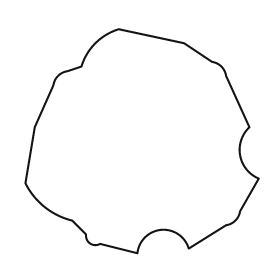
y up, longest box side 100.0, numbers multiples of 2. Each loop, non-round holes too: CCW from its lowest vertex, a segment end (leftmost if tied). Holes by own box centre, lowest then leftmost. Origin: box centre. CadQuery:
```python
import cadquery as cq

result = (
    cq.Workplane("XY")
    .moveTo(-2.0, -48.0)
    .threePointArc((8.0, -38.0), (20.0, -46.0))
    .lineTo(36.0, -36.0)
    .threePointArc((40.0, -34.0), (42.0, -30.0))
    .lineTo(50.0, -16.0)
    .threePointArc((42.0, -6.0), (46.0, 6.0))
    .lineTo(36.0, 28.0)
    .threePointArc((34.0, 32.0), (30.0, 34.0))
    .lineTo(18.0, 42.0)
    .lineTo(-10.0, 48.0)
    .threePointArc((-20.0, 42.0), (-26.0, 32.0))
    .lineTo(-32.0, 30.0)
    .threePointArc((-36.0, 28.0), (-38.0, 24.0))
    .lineTo(-46.0, 6.0)
    .lineTo(-50.0, -18.0)
    .threePointArc((-42.0, -28.0), (-30.0, -34.0))
    .lineTo(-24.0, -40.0)
    .threePointArc((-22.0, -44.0), (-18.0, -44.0))
    .close()
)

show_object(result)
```